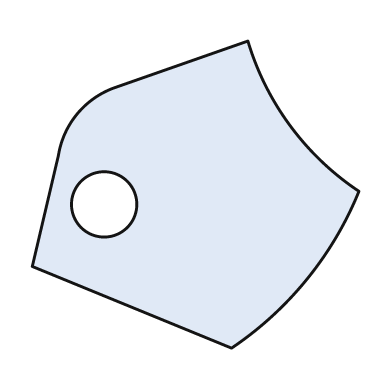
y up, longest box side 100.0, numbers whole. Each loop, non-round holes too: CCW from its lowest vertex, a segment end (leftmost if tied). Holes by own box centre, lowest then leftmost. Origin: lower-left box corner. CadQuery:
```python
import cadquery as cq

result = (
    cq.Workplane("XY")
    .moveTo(61.0, 0.0)
    .threePointArc((84.0, 21.0), (100.0, 48.0))
    .threePointArc((79.0, 68.0), (66.0, 94.0))
    .lineTo(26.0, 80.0)
    .threePointArc((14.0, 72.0), (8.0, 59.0))
    .lineTo(0.0, 25.0)
    .close()
    .moveTo(22.0, 44.0)
    .circle(10.0)
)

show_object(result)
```